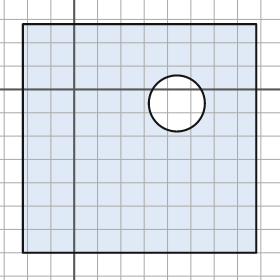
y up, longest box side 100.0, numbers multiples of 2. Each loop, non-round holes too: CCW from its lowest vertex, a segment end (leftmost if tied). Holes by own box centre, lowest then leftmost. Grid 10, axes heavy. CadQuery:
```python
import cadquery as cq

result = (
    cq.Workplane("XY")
    .moveTo(-22.0, -70.0)
    .lineTo(78.0, -70.0)
    .lineTo(78.0, 28.0)
    .lineTo(-22.0, 28.0)
    .close()
    .moveTo(44.0, -6.0)
    .circle(12.0)
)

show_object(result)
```